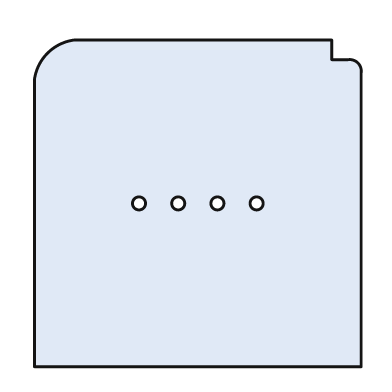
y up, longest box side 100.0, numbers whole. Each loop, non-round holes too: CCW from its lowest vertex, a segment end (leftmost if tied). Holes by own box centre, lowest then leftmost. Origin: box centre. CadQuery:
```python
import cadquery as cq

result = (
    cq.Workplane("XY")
    .moveTo(-50.0, -50.0)
    .lineTo(50.0, -50.0)
    .lineTo(50.0, 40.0)
    .threePointArc((49.0, 43.0), (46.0, 44.0))
    .lineTo(41.0, 44.0)
    .lineTo(41.0, 50.0)
    .lineTo(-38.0, 50.0)
    .threePointArc((-46.0, 46.0), (-50.0, 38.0))
    .close()
    .moveTo(-18.0, 0.0)
    .circle(2.0)
    .moveTo(-6.0, 0.0)
    .circle(2.0)
    .moveTo(6.0, 0.0)
    .circle(2.0)
    .moveTo(18.0, 0.0)
    .circle(2.0)
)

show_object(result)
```